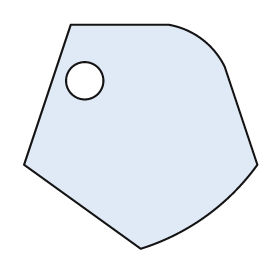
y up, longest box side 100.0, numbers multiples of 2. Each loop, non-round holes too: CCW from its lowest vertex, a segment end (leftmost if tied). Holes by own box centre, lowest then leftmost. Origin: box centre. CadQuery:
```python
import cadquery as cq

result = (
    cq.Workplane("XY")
    .moveTo(0.0, -48.0)
    .threePointArc((28.0, -34.0), (50.0, -12.0))
    .lineTo(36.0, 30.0)
    .threePointArc((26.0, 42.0), (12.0, 48.0))
    .lineTo(-30.0, 48.0)
    .lineTo(-50.0, -12.0)
    .close()
    .moveTo(-24.0, 24.0)
    .circle(8.0)
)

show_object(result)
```